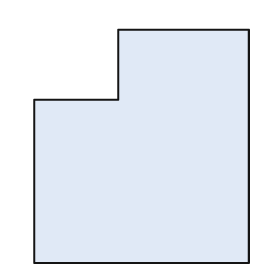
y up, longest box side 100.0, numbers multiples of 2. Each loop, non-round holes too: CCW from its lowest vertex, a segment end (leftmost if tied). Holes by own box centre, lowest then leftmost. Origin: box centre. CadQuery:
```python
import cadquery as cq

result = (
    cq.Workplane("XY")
    .moveTo(-46.0, -50.0)
    .lineTo(46.0, -50.0)
    .lineTo(46.0, 50.0)
    .lineTo(-10.0, 50.0)
    .lineTo(-10.0, 20.0)
    .lineTo(-46.0, 20.0)
    .close()
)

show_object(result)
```